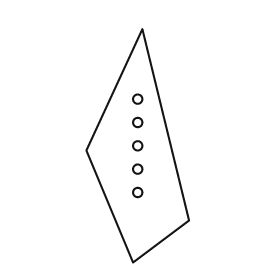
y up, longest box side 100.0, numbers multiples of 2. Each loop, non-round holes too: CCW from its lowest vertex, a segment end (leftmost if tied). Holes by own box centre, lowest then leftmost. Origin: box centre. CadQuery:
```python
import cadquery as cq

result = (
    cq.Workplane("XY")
    .moveTo(-2.0, -50.0)
    .lineTo(22.0, -32.0)
    .lineTo(2.0, 50.0)
    .lineTo(-22.0, -2.0)
    .close()
    .moveTo(0.0, -20.0)
    .circle(2.0)
    .moveTo(0.0, -10.0)
    .circle(2.0)
    .moveTo(0.0, 0.0)
    .circle(2.0)
    .moveTo(0.0, 10.0)
    .circle(2.0)
    .moveTo(0.0, 20.0)
    .circle(2.0)
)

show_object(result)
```